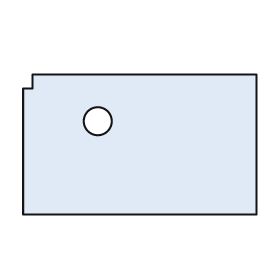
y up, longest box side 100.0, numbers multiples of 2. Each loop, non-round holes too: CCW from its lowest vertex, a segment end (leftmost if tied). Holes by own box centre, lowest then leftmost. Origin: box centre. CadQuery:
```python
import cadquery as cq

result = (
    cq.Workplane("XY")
    .moveTo(-50.0, -30.0)
    .lineTo(50.0, -30.0)
    .lineTo(50.0, 30.0)
    .lineTo(-46.0, 30.0)
    .lineTo(-46.0, 24.0)
    .lineTo(-50.0, 24.0)
    .close()
    .moveTo(-18.0, 10.0)
    .circle(6.0)
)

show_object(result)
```